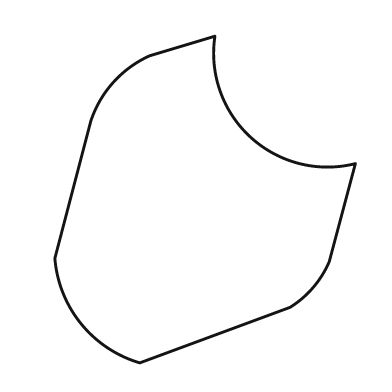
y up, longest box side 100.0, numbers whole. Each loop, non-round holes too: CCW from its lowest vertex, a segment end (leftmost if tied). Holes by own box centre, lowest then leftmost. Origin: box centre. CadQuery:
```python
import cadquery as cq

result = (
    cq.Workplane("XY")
    .moveTo(-20.0, -50.0)
    .lineTo(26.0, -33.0)
    .threePointArc((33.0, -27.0), (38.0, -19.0))
    .lineTo(46.0, 11.0)
    .threePointArc((14.0, 19.0), (3.0, 50.0))
    .lineTo(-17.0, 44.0)
    .threePointArc((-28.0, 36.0), (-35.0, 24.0))
    .lineTo(-46.0, -18.0)
    .threePointArc((-38.0, -38.0), (-20.0, -50.0))
    .close()
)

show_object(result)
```